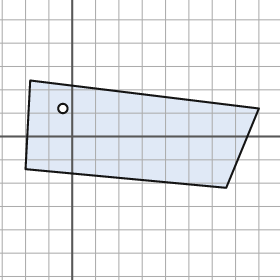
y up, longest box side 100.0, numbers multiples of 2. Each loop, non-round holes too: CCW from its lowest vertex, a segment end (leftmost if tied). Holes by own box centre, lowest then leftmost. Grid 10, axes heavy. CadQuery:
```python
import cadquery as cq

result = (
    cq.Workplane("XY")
    .moveTo(66.0, -22.0)
    .lineTo(80.0, 12.0)
    .lineTo(-18.0, 24.0)
    .lineTo(-20.0, -14.0)
    .close()
    .moveTo(-4.0, 12.0)
    .circle(2.0)
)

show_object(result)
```